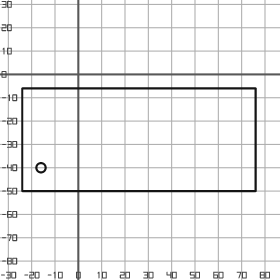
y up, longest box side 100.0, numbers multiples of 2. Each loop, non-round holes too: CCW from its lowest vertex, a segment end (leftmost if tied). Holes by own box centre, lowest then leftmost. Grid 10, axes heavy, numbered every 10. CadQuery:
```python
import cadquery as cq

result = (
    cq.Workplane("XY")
    .moveTo(-24.0, -50.0)
    .lineTo(76.0, -50.0)
    .lineTo(76.0, -6.0)
    .lineTo(-24.0, -6.0)
    .close()
    .moveTo(-16.0, -40.0)
    .circle(2.0)
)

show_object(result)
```